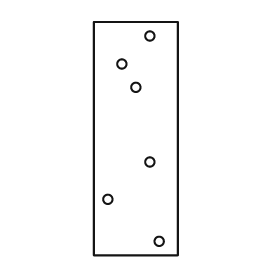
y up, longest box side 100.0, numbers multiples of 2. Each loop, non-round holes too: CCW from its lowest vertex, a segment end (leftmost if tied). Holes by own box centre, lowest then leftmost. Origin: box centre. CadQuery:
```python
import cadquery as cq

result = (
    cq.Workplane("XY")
    .moveTo(-18.0, -50.0)
    .lineTo(18.0, -50.0)
    .lineTo(18.0, 50.0)
    .lineTo(-18.0, 50.0)
    .close()
    .moveTo(10.0, -44.0)
    .circle(2.0)
    .moveTo(-12.0, -26.0)
    .circle(2.0)
    .moveTo(6.0, -10.0)
    .circle(2.0)
    .moveTo(0.0, 22.0)
    .circle(2.0)
    .moveTo(-6.0, 32.0)
    .circle(2.0)
    .moveTo(6.0, 44.0)
    .circle(2.0)
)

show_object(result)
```